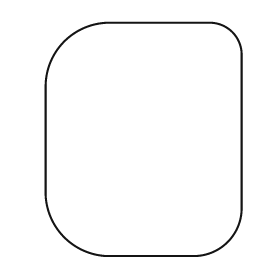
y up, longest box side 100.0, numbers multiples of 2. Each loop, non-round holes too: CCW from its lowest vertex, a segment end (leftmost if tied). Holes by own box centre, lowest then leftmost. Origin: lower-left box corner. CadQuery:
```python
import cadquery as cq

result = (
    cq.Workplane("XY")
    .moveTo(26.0, 0.0)
    .lineTo(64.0, 0.0)
    .threePointArc((78.0, 6.0), (84.0, 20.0))
    .lineTo(84.0, 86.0)
    .threePointArc((80.0, 96.0), (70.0, 100.0))
    .lineTo(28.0, 100.0)
    .threePointArc((8.0, 92.0), (0.0, 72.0))
    .lineTo(0.0, 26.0)
    .threePointArc((8.0, 8.0), (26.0, 0.0))
    .close()
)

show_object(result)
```